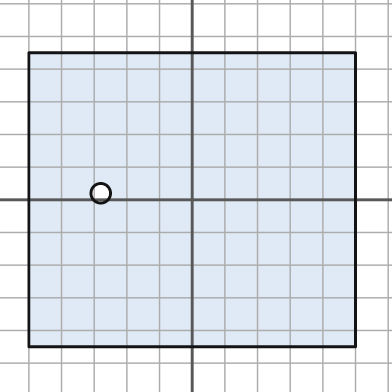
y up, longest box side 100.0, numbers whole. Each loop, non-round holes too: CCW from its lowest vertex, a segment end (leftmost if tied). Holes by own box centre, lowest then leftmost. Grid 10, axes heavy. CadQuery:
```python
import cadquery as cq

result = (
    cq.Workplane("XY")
    .moveTo(-50.0, -45.0)
    .lineTo(50.0, -45.0)
    .lineTo(50.0, 45.0)
    .lineTo(-50.0, 45.0)
    .close()
    .moveTo(-28.0, 2.0)
    .circle(3.0)
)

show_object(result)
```